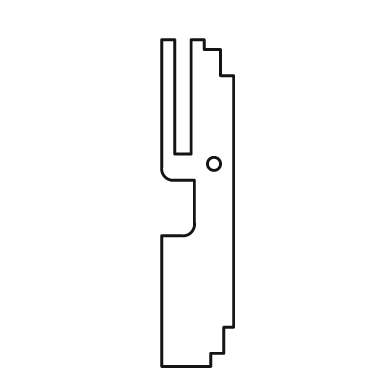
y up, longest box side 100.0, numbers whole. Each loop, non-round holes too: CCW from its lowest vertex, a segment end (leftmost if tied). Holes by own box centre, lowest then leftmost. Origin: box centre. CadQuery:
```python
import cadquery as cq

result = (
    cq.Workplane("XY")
    .moveTo(-11.0, -50.0)
    .lineTo(4.0, -50.0)
    .lineTo(4.0, -46.0)
    .lineTo(8.0, -46.0)
    .lineTo(8.0, -38.0)
    .lineTo(11.0, -38.0)
    .lineTo(11.0, 39.0)
    .lineTo(7.0, 39.0)
    .lineTo(7.0, 47.0)
    .lineTo(2.0, 47.0)
    .lineTo(2.0, 50.0)
    .lineTo(-2.0, 50.0)
    .lineTo(-2.0, 15.0)
    .lineTo(-7.0, 15.0)
    .lineTo(-7.0, 50.0)
    .lineTo(-11.0, 50.0)
    .lineTo(-11.0, 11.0)
    .threePointArc((-10.0, 8.0), (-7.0, 7.0))
    .lineTo(-1.0, 7.0)
    .lineTo(-1.0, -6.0)
    .threePointArc((-2.0, -9.0), (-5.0, -10.0))
    .lineTo(-11.0, -10.0)
    .close()
    .moveTo(5.0, 12.0)
    .circle(2.0)
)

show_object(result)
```